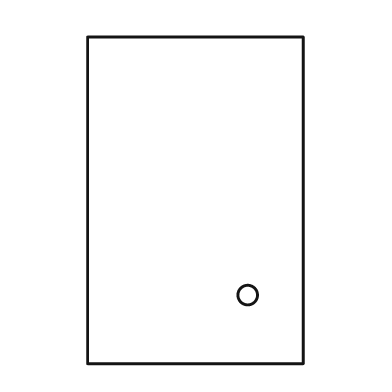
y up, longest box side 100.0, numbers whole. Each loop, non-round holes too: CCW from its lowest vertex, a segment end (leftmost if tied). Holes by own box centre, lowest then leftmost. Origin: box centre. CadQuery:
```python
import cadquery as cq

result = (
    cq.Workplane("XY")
    .moveTo(-33.0, -50.0)
    .lineTo(33.0, -50.0)
    .lineTo(33.0, 50.0)
    .lineTo(-33.0, 50.0)
    .close()
    .moveTo(16.0, -29.0)
    .circle(3.0)
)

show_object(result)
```